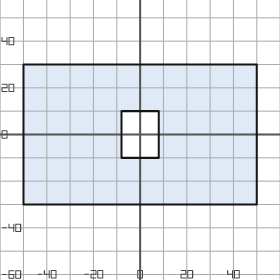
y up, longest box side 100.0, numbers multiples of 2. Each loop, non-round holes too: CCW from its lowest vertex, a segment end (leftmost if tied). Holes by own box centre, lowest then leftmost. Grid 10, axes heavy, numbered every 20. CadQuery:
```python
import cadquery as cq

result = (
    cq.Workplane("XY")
    .moveTo(-50.0, -30.0)
    .lineTo(50.0, -30.0)
    .lineTo(50.0, 30.0)
    .lineTo(-50.0, 30.0)
    .close()
    .moveTo(-8.0, -10.0)
    .lineTo(8.0, -10.0)
    .lineTo(8.0, 10.0)
    .lineTo(-8.0, 10.0)
    .close()
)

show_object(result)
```